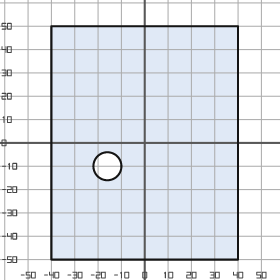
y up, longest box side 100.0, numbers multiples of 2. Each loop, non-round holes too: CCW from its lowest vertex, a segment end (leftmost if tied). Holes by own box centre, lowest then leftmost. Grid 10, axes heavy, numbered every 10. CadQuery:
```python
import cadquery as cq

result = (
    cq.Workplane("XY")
    .moveTo(-40.0, -50.0)
    .lineTo(40.0, -50.0)
    .lineTo(40.0, 50.0)
    .lineTo(-40.0, 50.0)
    .close()
    .moveTo(-16.0, -10.0)
    .circle(6.0)
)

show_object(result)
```